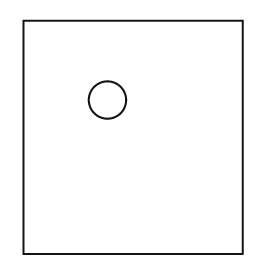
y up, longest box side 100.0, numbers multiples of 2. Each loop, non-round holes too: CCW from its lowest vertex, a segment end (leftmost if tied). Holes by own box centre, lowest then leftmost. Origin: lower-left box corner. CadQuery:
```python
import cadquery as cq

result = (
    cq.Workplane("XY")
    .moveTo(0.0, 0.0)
    .lineTo(94.0, 0.0)
    .lineTo(94.0, 100.0)
    .lineTo(0.0, 100.0)
    .close()
    .moveTo(36.0, 66.0)
    .circle(8.0)
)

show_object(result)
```